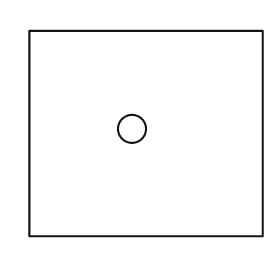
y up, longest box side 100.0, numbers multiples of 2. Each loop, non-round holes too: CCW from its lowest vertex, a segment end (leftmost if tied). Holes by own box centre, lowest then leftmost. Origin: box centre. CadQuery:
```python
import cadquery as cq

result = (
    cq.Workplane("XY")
    .moveTo(-50.0, -44.0)
    .lineTo(50.0, -44.0)
    .lineTo(50.0, 44.0)
    .lineTo(-50.0, 44.0)
    .close()
    .moveTo(-6.0, 2.0)
    .circle(6.0)
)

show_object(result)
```